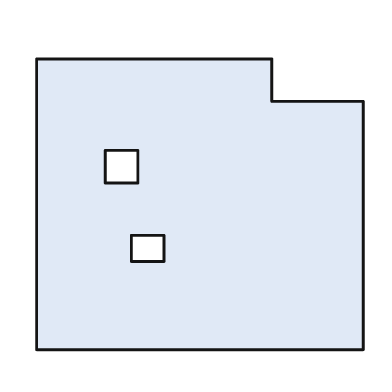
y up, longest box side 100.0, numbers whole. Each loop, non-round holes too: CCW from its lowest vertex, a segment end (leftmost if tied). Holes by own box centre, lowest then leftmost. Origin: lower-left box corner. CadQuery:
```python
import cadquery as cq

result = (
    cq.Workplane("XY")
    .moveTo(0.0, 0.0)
    .lineTo(100.0, 0.0)
    .lineTo(100.0, 76.0)
    .lineTo(72.0, 76.0)
    .lineTo(72.0, 89.0)
    .lineTo(0.0, 89.0)
    .close()
    .moveTo(29.0, 27.0)
    .lineTo(39.0, 27.0)
    .lineTo(39.0, 35.0)
    .lineTo(29.0, 35.0)
    .close()
    .moveTo(21.0, 51.0)
    .lineTo(31.0, 51.0)
    .lineTo(31.0, 61.0)
    .lineTo(21.0, 61.0)
    .close()
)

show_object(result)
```